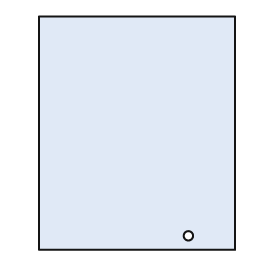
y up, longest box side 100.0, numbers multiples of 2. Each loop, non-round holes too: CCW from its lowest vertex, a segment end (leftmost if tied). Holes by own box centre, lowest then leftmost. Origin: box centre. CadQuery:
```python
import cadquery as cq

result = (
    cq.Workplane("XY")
    .moveTo(-42.0, -50.0)
    .lineTo(42.0, -50.0)
    .lineTo(42.0, 50.0)
    .lineTo(-42.0, 50.0)
    .close()
    .moveTo(22.0, -44.0)
    .circle(2.0)
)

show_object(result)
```